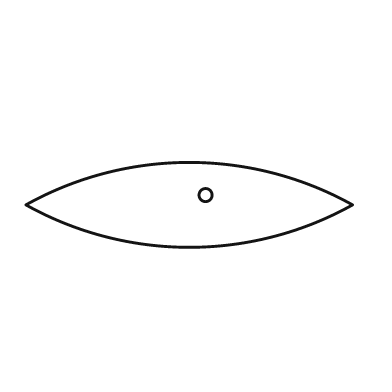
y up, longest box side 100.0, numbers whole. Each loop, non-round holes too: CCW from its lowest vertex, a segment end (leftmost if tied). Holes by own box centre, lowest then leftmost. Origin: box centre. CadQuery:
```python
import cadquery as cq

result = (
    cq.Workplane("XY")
    .moveTo(-50.0, 0.0)
    .threePointArc((0.0, -13.0), (50.0, 0.0))
    .threePointArc((0.0, 13.0), (-50.0, 0.0))
    .close()
    .moveTo(5.0, 3.0)
    .circle(2.0)
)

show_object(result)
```